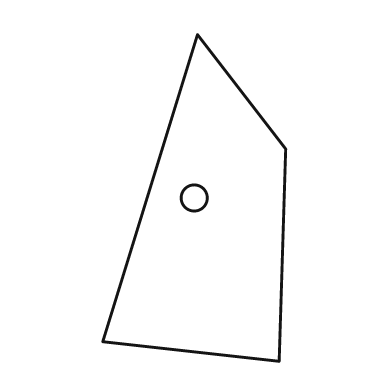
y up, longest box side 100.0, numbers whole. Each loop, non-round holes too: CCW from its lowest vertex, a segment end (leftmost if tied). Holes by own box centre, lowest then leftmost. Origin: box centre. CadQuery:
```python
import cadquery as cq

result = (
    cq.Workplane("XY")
    .moveTo(26.0, -50.0)
    .lineTo(28.0, 15.0)
    .lineTo(1.0, 50.0)
    .lineTo(-28.0, -44.0)
    .close()
    .moveTo(0.0, 0.0)
    .circle(4.0)
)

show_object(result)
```